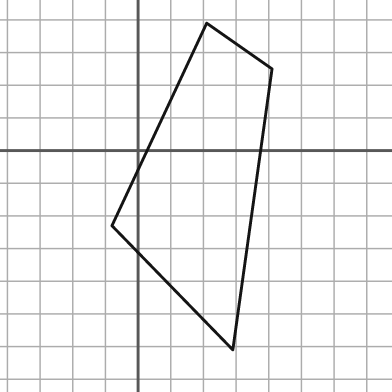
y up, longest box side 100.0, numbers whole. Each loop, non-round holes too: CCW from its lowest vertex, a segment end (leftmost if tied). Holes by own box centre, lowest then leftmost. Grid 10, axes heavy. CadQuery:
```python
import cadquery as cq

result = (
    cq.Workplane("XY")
    .moveTo(29.0, -61.0)
    .lineTo(41.0, 25.0)
    .lineTo(21.0, 39.0)
    .lineTo(-8.0, -23.0)
    .close()
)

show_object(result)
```